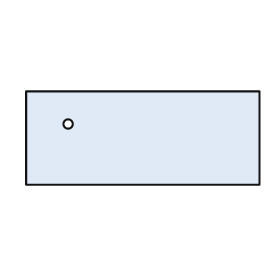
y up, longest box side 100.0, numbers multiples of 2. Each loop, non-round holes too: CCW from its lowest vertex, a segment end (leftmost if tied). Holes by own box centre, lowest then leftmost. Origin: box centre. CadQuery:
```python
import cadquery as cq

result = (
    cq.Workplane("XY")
    .moveTo(-50.0, -20.0)
    .lineTo(50.0, -20.0)
    .lineTo(50.0, 20.0)
    .lineTo(-50.0, 20.0)
    .close()
    .moveTo(-32.0, 6.0)
    .circle(2.0)
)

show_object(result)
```